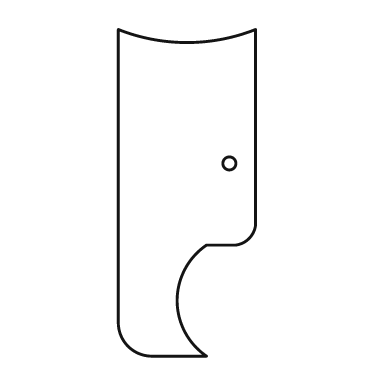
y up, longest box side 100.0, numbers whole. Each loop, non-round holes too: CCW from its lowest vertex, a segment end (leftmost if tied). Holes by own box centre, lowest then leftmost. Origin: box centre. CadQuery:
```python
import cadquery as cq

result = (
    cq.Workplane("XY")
    .moveTo(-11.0, -50.0)
    .lineTo(6.0, -50.0)
    .threePointArc((-3.0, -33.0), (6.0, -16.0))
    .lineTo(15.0, -16.0)
    .threePointArc((19.0, -14.0), (21.0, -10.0))
    .lineTo(21.0, 50.0)
    .threePointArc((0.0, 46.0), (-21.0, 50.0))
    .lineTo(-21.0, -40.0)
    .threePointArc((-18.0, -47.0), (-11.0, -50.0))
    .close()
    .moveTo(13.0, 9.0)
    .circle(2.0)
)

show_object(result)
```